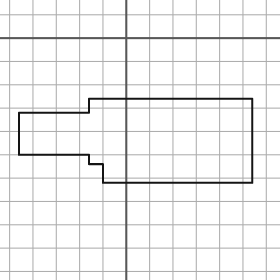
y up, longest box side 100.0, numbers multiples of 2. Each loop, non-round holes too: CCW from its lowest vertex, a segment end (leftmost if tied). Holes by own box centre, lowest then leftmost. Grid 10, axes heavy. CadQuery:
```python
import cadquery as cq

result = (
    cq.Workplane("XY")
    .moveTo(-10.0, -62.0)
    .lineTo(54.0, -62.0)
    .lineTo(54.0, -26.0)
    .lineTo(-16.0, -26.0)
    .lineTo(-16.0, -32.0)
    .lineTo(-46.0, -32.0)
    .lineTo(-46.0, -50.0)
    .lineTo(-16.0, -50.0)
    .lineTo(-16.0, -54.0)
    .lineTo(-10.0, -54.0)
    .close()
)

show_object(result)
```